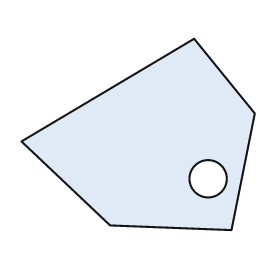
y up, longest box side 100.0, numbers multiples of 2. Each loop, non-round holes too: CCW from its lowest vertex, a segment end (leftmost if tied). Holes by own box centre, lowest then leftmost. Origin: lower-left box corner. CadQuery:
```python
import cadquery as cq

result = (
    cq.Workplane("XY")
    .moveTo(90.0, 0.0)
    .lineTo(100.0, 50.0)
    .lineTo(74.0, 82.0)
    .lineTo(0.0, 38.0)
    .lineTo(38.0, 2.0)
    .close()
    .moveTo(80.0, 22.0)
    .circle(8.0)
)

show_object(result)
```